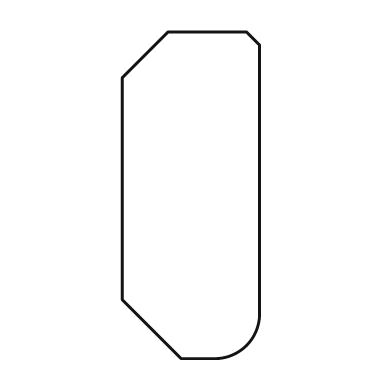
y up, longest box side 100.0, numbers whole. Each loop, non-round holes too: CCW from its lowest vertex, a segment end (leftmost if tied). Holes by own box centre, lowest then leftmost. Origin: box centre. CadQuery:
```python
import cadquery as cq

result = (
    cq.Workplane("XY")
    .moveTo(-3.0, -50.0)
    .lineTo(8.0, -50.0)
    .threePointArc((17.0, -46.0), (21.0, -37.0))
    .lineTo(21.0, 46.0)
    .lineTo(17.0, 50.0)
    .lineTo(-7.0, 50.0)
    .lineTo(-21.0, 36.0)
    .lineTo(-21.0, -32.0)
    .close()
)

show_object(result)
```